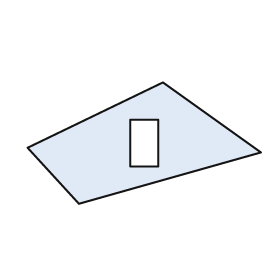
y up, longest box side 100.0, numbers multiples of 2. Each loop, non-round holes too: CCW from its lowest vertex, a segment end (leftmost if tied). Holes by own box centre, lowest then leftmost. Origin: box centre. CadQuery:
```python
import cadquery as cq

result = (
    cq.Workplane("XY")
    .moveTo(-28.0, -26.0)
    .lineTo(50.0, -4.0)
    .lineTo(8.0, 26.0)
    .lineTo(-50.0, -2.0)
    .close()
    .moveTo(-6.0, -10.0)
    .lineTo(6.0, -10.0)
    .lineTo(6.0, 10.0)
    .lineTo(-6.0, 10.0)
    .close()
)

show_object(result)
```